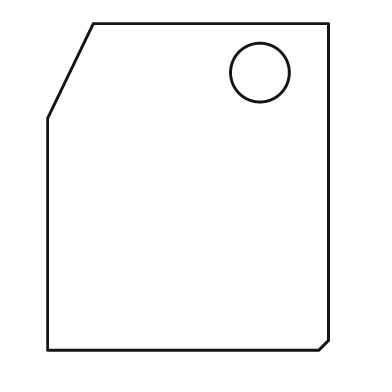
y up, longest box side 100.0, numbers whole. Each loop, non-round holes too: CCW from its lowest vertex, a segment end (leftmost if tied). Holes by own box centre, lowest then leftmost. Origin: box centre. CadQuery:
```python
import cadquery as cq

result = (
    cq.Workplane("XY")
    .moveTo(-43.0, -50.0)
    .lineTo(40.0, -50.0)
    .lineTo(43.0, -47.0)
    .lineTo(43.0, 50.0)
    .lineTo(-29.0, 50.0)
    .lineTo(-43.0, 21.0)
    .close()
    .moveTo(22.0, 35.0)
    .circle(9.0)
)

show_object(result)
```